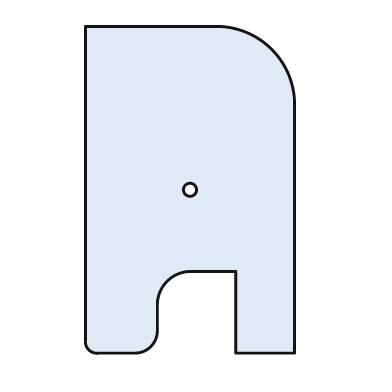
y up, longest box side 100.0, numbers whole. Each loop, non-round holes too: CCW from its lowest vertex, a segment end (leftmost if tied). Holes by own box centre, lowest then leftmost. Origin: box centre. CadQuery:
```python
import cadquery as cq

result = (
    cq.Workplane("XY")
    .moveTo(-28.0, -50.0)
    .lineTo(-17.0, -50.0)
    .threePointArc((-12.0, -48.0), (-10.0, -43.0))
    .lineTo(-10.0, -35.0)
    .threePointArc((-7.0, -28.0), (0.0, -25.0))
    .lineTo(14.0, -25.0)
    .lineTo(14.0, -50.0)
    .lineTo(32.0, -50.0)
    .lineTo(32.0, 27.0)
    .threePointArc((25.0, 43.0), (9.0, 50.0))
    .lineTo(-32.0, 50.0)
    .lineTo(-32.0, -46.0)
    .threePointArc((-31.0, -49.0), (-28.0, -50.0))
    .close()
    .moveTo(0.0, 0.0)
    .circle(2.0)
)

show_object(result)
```